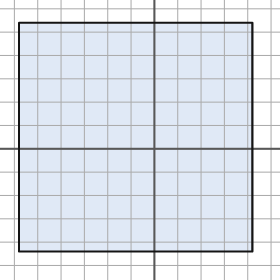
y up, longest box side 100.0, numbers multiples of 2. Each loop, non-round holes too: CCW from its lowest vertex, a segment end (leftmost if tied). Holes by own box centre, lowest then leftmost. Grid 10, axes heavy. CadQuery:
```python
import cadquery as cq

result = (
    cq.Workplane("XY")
    .moveTo(-58.0, -44.0)
    .lineTo(42.0, -44.0)
    .lineTo(42.0, 54.0)
    .lineTo(-58.0, 54.0)
    .close()
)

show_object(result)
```